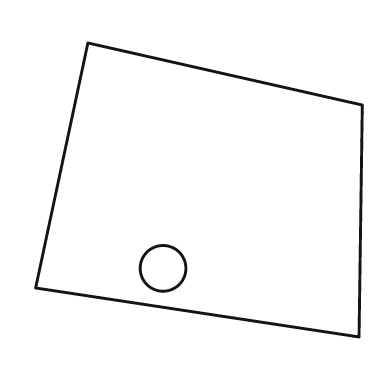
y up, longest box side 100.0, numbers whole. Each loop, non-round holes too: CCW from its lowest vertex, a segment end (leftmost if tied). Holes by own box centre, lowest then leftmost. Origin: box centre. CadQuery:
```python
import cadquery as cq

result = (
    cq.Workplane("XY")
    .moveTo(49.0, -45.0)
    .lineTo(50.0, 26.0)
    .lineTo(-34.0, 45.0)
    .lineTo(-50.0, -30.0)
    .close()
    .moveTo(-11.0, -24.0)
    .circle(7.0)
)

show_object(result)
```